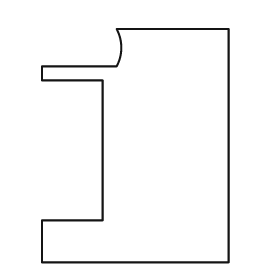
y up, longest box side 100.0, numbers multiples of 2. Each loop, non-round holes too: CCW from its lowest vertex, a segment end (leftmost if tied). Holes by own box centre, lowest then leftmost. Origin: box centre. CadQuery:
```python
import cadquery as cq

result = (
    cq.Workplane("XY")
    .moveTo(-40.0, -50.0)
    .lineTo(40.0, -50.0)
    .lineTo(40.0, 50.0)
    .lineTo(-8.0, 50.0)
    .threePointArc((-6.0, 42.0), (-8.0, 34.0))
    .lineTo(-40.0, 34.0)
    .lineTo(-40.0, 28.0)
    .lineTo(-14.0, 28.0)
    .lineTo(-14.0, -32.0)
    .lineTo(-40.0, -32.0)
    .close()
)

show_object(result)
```